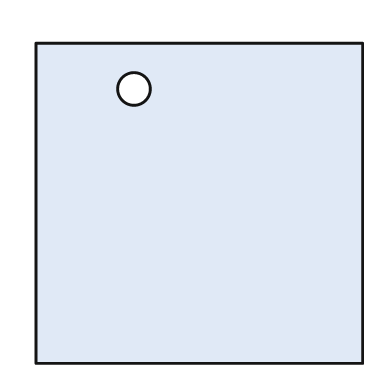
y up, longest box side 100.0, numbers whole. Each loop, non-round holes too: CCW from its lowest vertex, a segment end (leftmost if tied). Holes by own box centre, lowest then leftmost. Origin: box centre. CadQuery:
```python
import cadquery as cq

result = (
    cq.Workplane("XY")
    .moveTo(-50.0, -49.0)
    .lineTo(50.0, -49.0)
    .lineTo(50.0, 49.0)
    .lineTo(-50.0, 49.0)
    .close()
    .moveTo(-20.0, 35.0)
    .circle(5.0)
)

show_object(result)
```